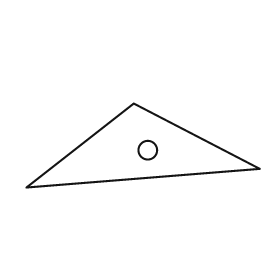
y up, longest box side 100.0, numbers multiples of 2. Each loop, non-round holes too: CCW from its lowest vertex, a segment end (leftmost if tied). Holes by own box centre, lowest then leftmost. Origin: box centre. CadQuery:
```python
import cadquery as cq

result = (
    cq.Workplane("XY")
    .moveTo(-50.0, -18.0)
    .lineTo(50.0, -10.0)
    .lineTo(-4.0, 18.0)
    .close()
    .moveTo(2.0, -2.0)
    .circle(4.0)
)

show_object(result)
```